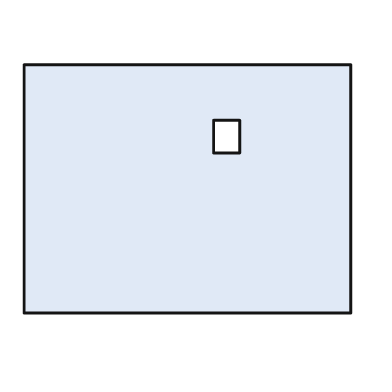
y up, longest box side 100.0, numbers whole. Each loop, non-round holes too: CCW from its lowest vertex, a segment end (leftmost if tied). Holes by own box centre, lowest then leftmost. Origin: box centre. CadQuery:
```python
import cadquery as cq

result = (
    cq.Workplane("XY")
    .moveTo(-50.0, -38.0)
    .lineTo(50.0, -38.0)
    .lineTo(50.0, 38.0)
    .lineTo(-50.0, 38.0)
    .close()
    .moveTo(8.0, 11.0)
    .lineTo(16.0, 11.0)
    .lineTo(16.0, 21.0)
    .lineTo(8.0, 21.0)
    .close()
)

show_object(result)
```